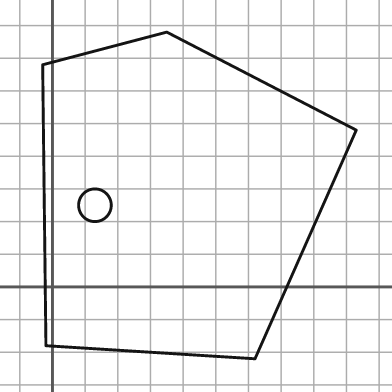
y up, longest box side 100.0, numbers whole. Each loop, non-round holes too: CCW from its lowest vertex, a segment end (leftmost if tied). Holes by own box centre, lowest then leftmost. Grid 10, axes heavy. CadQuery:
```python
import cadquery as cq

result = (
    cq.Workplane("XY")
    .moveTo(62.0, -22.0)
    .lineTo(93.0, 48.0)
    .lineTo(35.0, 78.0)
    .lineTo(-3.0, 68.0)
    .lineTo(-2.0, -18.0)
    .close()
    .moveTo(13.0, 25.0)
    .circle(5.0)
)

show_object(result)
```